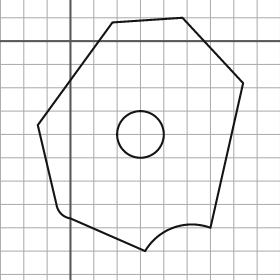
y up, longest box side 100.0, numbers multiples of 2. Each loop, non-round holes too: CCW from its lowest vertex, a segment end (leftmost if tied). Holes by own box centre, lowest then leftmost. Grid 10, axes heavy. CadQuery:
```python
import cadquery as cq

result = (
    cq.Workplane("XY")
    .moveTo(32.0, -90.0)
    .threePointArc((44.0, -80.0), (60.0, -80.0))
    .lineTo(74.0, -18.0)
    .lineTo(48.0, 10.0)
    .lineTo(18.0, 8.0)
    .lineTo(-14.0, -36.0)
    .lineTo(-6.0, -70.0)
    .threePointArc((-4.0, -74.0), (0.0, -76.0))
    .close()
    .moveTo(30.0, -40.0)
    .circle(10.0)
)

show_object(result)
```